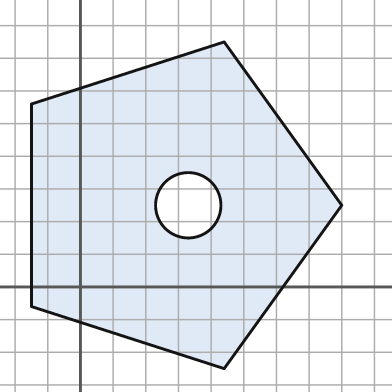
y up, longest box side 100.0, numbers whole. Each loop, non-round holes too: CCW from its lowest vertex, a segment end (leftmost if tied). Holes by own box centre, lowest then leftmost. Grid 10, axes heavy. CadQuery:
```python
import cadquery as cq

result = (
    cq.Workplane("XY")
    .moveTo(44.0, -25.0)
    .lineTo(80.0, 25.0)
    .lineTo(44.0, 75.0)
    .lineTo(-15.0, 56.0)
    .lineTo(-15.0, -6.0)
    .close()
    .moveTo(33.0, 25.0)
    .circle(10.0)
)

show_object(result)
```